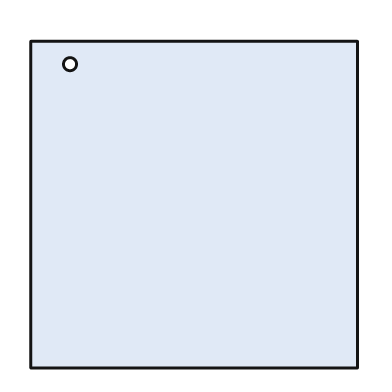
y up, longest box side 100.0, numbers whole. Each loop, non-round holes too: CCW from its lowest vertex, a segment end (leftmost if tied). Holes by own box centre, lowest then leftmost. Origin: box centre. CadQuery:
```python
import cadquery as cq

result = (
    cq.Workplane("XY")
    .moveTo(-50.0, -50.0)
    .lineTo(50.0, -50.0)
    .lineTo(50.0, 50.0)
    .lineTo(-50.0, 50.0)
    .close()
    .moveTo(-38.0, 43.0)
    .circle(2.0)
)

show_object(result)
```